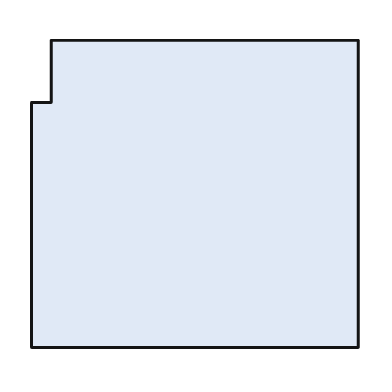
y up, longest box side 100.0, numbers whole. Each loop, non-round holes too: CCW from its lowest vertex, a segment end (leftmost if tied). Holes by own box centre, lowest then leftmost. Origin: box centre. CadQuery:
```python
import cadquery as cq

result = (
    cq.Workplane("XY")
    .moveTo(-50.0, -47.0)
    .lineTo(50.0, -47.0)
    .lineTo(50.0, 47.0)
    .lineTo(-44.0, 47.0)
    .lineTo(-44.0, 28.0)
    .lineTo(-50.0, 28.0)
    .close()
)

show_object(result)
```